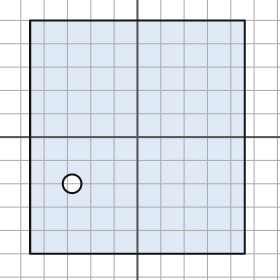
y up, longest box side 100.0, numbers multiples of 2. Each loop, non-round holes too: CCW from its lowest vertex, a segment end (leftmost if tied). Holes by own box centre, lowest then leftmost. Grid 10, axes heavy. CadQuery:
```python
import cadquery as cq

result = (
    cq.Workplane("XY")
    .moveTo(-46.0, -50.0)
    .lineTo(46.0, -50.0)
    .lineTo(46.0, 50.0)
    .lineTo(-46.0, 50.0)
    .close()
    .moveTo(-28.0, -20.0)
    .circle(4.0)
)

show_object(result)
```